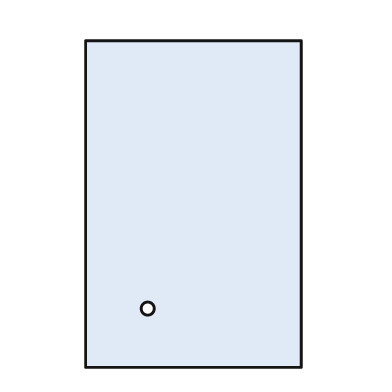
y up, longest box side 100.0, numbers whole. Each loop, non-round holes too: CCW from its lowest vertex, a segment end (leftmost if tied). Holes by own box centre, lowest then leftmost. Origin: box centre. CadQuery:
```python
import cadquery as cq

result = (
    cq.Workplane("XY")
    .moveTo(-33.0, -50.0)
    .lineTo(33.0, -50.0)
    .lineTo(33.0, 50.0)
    .lineTo(-33.0, 50.0)
    .close()
    .moveTo(-14.0, -32.0)
    .circle(2.0)
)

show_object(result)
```